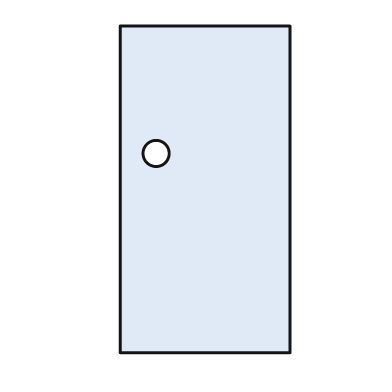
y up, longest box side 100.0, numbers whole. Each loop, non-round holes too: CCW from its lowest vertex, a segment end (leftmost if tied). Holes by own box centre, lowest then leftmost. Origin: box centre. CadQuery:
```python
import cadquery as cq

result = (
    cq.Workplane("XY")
    .moveTo(-26.0, -50.0)
    .lineTo(26.0, -50.0)
    .lineTo(26.0, 50.0)
    .lineTo(-26.0, 50.0)
    .close()
    .moveTo(-15.0, 11.0)
    .circle(4.0)
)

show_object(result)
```